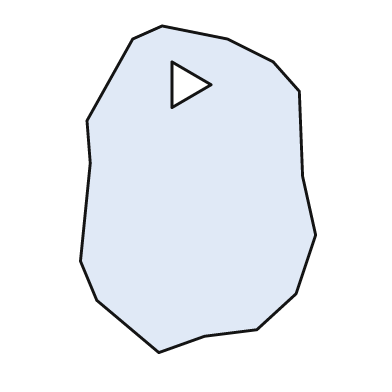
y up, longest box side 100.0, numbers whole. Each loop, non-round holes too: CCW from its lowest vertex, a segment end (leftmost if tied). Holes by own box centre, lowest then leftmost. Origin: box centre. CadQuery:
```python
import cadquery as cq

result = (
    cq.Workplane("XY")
    .moveTo(-12.0, -50.0)
    .lineTo(2.0, -45.0)
    .lineTo(18.0, -43.0)
    .lineTo(30.0, -32.0)
    .lineTo(36.0, -14.0)
    .lineTo(32.0, 4.0)
    .lineTo(31.0, 30.0)
    .lineTo(23.0, 39.0)
    .lineTo(9.0, 46.0)
    .lineTo(-11.0, 50.0)
    .lineTo(-20.0, 46.0)
    .lineTo(-34.0, 21.0)
    .lineTo(-33.0, 8.0)
    .lineTo(-36.0, -22.0)
    .lineTo(-31.0, -34.0)
    .close()
    .moveTo(-8.0, 25.0)
    .lineTo(4.0, 32.0)
    .lineTo(-8.0, 39.0)
    .close()
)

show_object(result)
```